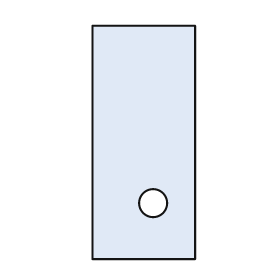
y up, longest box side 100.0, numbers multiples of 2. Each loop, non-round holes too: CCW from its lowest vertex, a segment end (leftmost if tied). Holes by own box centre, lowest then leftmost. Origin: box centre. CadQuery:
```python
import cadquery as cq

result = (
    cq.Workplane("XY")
    .moveTo(-22.0, -50.0)
    .lineTo(22.0, -50.0)
    .lineTo(22.0, 50.0)
    .lineTo(-22.0, 50.0)
    .close()
    .moveTo(4.0, -26.0)
    .circle(6.0)
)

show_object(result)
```